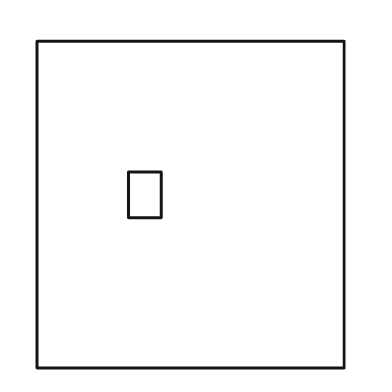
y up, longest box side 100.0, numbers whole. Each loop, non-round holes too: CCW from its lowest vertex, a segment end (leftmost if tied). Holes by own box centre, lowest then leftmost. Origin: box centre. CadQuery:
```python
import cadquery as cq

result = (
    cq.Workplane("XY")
    .moveTo(-47.0, -50.0)
    .lineTo(47.0, -50.0)
    .lineTo(47.0, 50.0)
    .lineTo(-47.0, 50.0)
    .close()
    .moveTo(-19.0, -4.0)
    .lineTo(-9.0, -4.0)
    .lineTo(-9.0, 10.0)
    .lineTo(-19.0, 10.0)
    .close()
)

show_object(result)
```